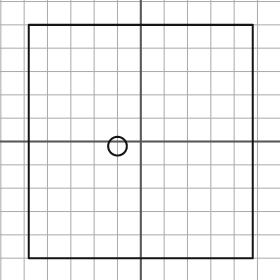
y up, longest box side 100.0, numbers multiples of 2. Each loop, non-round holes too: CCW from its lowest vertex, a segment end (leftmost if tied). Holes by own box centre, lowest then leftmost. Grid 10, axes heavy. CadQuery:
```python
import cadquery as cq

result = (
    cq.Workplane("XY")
    .moveTo(-48.0, -50.0)
    .lineTo(48.0, -50.0)
    .lineTo(48.0, 50.0)
    .lineTo(-48.0, 50.0)
    .close()
    .moveTo(-10.0, -2.0)
    .circle(4.0)
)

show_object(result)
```